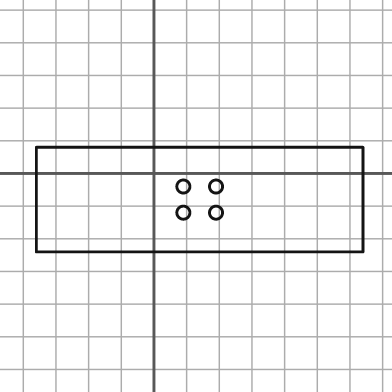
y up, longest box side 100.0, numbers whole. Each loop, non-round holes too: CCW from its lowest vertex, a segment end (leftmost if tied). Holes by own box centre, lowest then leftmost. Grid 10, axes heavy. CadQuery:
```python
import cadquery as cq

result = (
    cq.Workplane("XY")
    .moveTo(-36.0, -24.0)
    .lineTo(64.0, -24.0)
    .lineTo(64.0, 8.0)
    .lineTo(-36.0, 8.0)
    .close()
    .moveTo(9.0, -12.0)
    .circle(2.0)
    .moveTo(19.0, -12.0)
    .circle(2.0)
    .moveTo(9.0, -4.0)
    .circle(2.0)
    .moveTo(19.0, -4.0)
    .circle(2.0)
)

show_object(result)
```